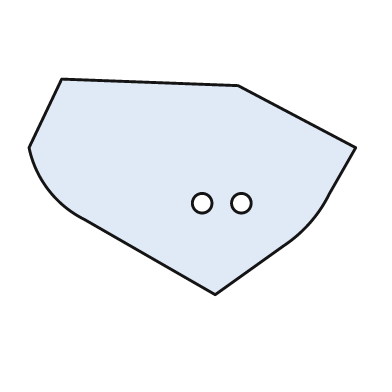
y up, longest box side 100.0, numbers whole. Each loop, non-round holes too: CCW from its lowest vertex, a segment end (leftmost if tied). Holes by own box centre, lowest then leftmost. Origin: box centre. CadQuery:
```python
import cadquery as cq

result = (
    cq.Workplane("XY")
    .moveTo(7.0, -33.0)
    .lineTo(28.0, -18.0)
    .threePointArc((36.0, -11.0), (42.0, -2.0))
    .lineTo(50.0, 12.0)
    .lineTo(14.0, 31.0)
    .lineTo(-40.0, 33.0)
    .lineTo(-50.0, 12.0)
    .threePointArc((-44.0, -1.0), (-33.0, -10.0))
    .close()
    .moveTo(3.0, -5.0)
    .circle(3.0)
    .moveTo(15.0, -5.0)
    .circle(3.0)
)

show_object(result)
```